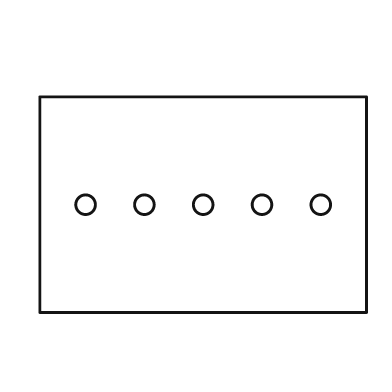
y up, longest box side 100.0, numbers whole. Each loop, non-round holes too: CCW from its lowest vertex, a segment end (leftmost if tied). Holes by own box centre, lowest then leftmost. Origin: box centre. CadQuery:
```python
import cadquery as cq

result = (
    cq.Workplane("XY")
    .moveTo(-50.0, -33.0)
    .lineTo(50.0, -33.0)
    .lineTo(50.0, 33.0)
    .lineTo(-50.0, 33.0)
    .close()
    .moveTo(-36.0, 0.0)
    .circle(3.0)
    .moveTo(-18.0, 0.0)
    .circle(3.0)
    .moveTo(0.0, 0.0)
    .circle(3.0)
    .moveTo(18.0, 0.0)
    .circle(3.0)
    .moveTo(36.0, 0.0)
    .circle(3.0)
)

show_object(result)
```